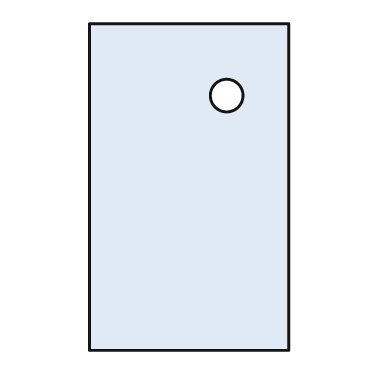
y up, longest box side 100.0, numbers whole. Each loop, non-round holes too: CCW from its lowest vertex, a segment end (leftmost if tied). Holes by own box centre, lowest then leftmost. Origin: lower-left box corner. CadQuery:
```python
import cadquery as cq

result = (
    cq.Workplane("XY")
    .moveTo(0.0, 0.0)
    .lineTo(61.0, 0.0)
    .lineTo(61.0, 100.0)
    .lineTo(0.0, 100.0)
    .close()
    .moveTo(42.0, 78.0)
    .circle(5.0)
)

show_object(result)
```